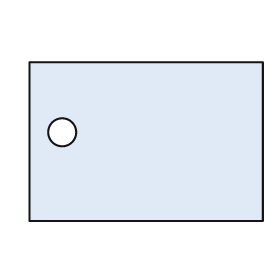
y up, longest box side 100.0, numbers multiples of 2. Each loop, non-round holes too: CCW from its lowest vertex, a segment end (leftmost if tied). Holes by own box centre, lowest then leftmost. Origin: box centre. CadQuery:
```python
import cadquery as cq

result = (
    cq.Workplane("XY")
    .moveTo(-50.0, -34.0)
    .lineTo(50.0, -34.0)
    .lineTo(50.0, 34.0)
    .lineTo(-50.0, 34.0)
    .close()
    .moveTo(-36.0, 4.0)
    .circle(6.0)
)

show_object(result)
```